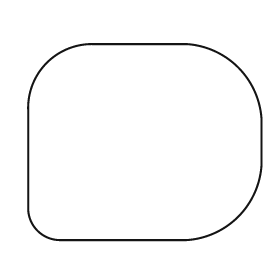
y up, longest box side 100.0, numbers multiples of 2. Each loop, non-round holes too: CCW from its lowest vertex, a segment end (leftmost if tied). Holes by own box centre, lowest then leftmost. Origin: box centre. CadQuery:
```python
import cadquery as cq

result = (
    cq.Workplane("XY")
    .moveTo(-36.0, -42.0)
    .lineTo(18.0, -42.0)
    .threePointArc((40.0, -32.0), (50.0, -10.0))
    .lineTo(50.0, 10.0)
    .threePointArc((40.0, 32.0), (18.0, 42.0))
    .lineTo(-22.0, 42.0)
    .threePointArc((-42.0, 34.0), (-50.0, 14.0))
    .lineTo(-50.0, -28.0)
    .threePointArc((-46.0, -38.0), (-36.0, -42.0))
    .close()
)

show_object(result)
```